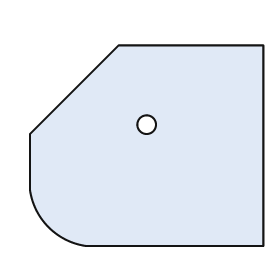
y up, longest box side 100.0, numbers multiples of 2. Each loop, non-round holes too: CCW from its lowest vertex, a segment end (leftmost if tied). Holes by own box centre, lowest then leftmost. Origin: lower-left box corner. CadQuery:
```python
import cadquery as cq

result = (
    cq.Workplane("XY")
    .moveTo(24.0, 0.0)
    .lineTo(100.0, 0.0)
    .lineTo(100.0, 86.0)
    .lineTo(38.0, 86.0)
    .lineTo(0.0, 48.0)
    .lineTo(0.0, 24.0)
    .threePointArc((8.0, 8.0), (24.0, 0.0))
    .close()
    .moveTo(50.0, 52.0)
    .circle(4.0)
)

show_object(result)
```